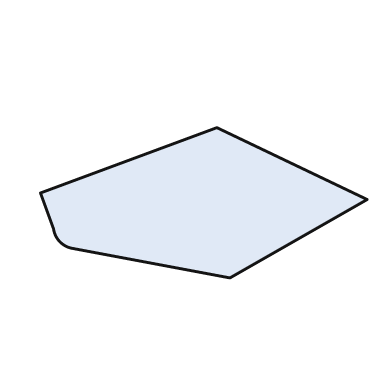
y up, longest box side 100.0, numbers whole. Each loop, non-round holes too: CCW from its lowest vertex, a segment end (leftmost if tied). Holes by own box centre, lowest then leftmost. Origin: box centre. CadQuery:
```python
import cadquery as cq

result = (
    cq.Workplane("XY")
    .moveTo(8.0, -23.0)
    .lineTo(50.0, 1.0)
    .lineTo(4.0, 23.0)
    .lineTo(-50.0, 3.0)
    .lineTo(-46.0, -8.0)
    .threePointArc((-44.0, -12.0), (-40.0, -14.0))
    .close()
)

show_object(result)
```